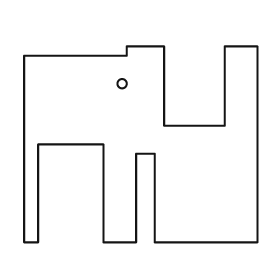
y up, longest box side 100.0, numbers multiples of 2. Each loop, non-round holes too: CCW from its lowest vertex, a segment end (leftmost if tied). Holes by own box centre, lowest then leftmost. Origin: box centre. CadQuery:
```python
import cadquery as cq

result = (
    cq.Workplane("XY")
    .moveTo(-50.0, -42.0)
    .lineTo(-44.0, -42.0)
    .lineTo(-44.0, 0.0)
    .lineTo(-16.0, 0.0)
    .lineTo(-16.0, -42.0)
    .lineTo(-2.0, -42.0)
    .lineTo(-2.0, -4.0)
    .lineTo(6.0, -4.0)
    .lineTo(6.0, -42.0)
    .lineTo(50.0, -42.0)
    .lineTo(50.0, 42.0)
    .lineTo(36.0, 42.0)
    .lineTo(36.0, 8.0)
    .lineTo(10.0, 8.0)
    .lineTo(10.0, 42.0)
    .lineTo(-6.0, 42.0)
    .lineTo(-6.0, 38.0)
    .lineTo(-50.0, 38.0)
    .close()
    .moveTo(-8.0, 26.0)
    .circle(2.0)
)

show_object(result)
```